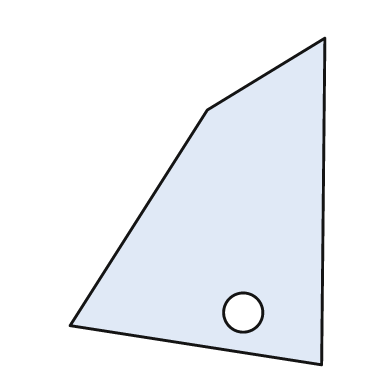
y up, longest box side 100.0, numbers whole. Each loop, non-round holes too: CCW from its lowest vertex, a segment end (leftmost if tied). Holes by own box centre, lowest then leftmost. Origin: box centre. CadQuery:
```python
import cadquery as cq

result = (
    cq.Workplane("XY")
    .moveTo(38.0, -50.0)
    .lineTo(39.0, 50.0)
    .lineTo(3.0, 28.0)
    .lineTo(-39.0, -38.0)
    .close()
    .moveTo(14.0, -34.0)
    .circle(6.0)
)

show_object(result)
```